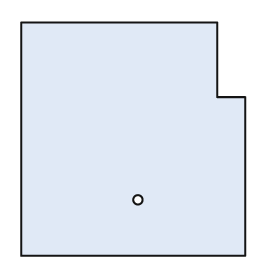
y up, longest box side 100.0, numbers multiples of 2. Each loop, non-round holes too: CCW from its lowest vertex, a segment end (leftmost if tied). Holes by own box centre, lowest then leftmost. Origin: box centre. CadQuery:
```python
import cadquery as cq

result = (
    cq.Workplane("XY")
    .moveTo(-48.0, -50.0)
    .lineTo(48.0, -50.0)
    .lineTo(48.0, 18.0)
    .lineTo(36.0, 18.0)
    .lineTo(36.0, 50.0)
    .lineTo(-48.0, 50.0)
    .close()
    .moveTo(2.0, -26.0)
    .circle(2.0)
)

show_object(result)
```